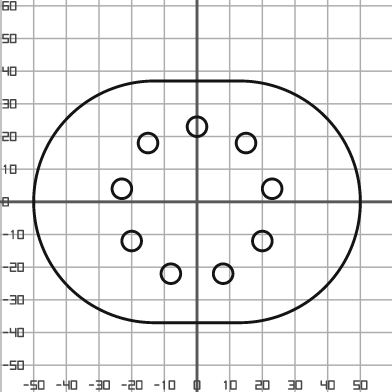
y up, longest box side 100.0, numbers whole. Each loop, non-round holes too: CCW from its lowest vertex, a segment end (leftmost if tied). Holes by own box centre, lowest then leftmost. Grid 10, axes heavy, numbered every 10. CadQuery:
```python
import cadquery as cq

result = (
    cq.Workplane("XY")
    .moveTo(-13.0, -37.0)
    .lineTo(13.0, -37.0)
    .threePointArc((50.0, 0.0), (13.0, 37.0))
    .lineTo(-13.0, 37.0)
    .threePointArc((-50.0, 0.0), (-13.0, -37.0))
    .close()
    .moveTo(-8.0, -22.0)
    .circle(3.0)
    .moveTo(8.0, -22.0)
    .circle(3.0)
    .moveTo(-20.0, -12.0)
    .circle(3.0)
    .moveTo(20.0, -12.0)
    .circle(3.0)
    .moveTo(-23.0, 4.0)
    .circle(3.0)
    .moveTo(23.0, 4.0)
    .circle(3.0)
    .moveTo(-15.0, 18.0)
    .circle(3.0)
    .moveTo(15.0, 18.0)
    .circle(3.0)
    .moveTo(0.0, 23.0)
    .circle(3.0)
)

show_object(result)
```